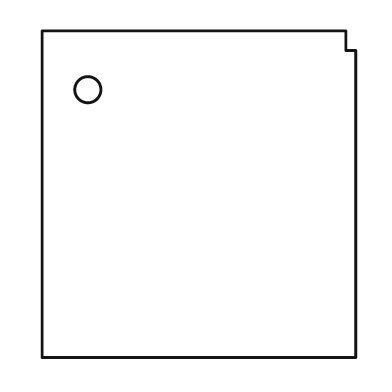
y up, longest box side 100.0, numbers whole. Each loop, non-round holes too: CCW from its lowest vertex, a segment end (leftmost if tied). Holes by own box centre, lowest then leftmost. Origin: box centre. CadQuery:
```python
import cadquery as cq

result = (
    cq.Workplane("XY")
    .moveTo(-48.0, -50.0)
    .lineTo(48.0, -50.0)
    .lineTo(48.0, 44.0)
    .lineTo(45.0, 44.0)
    .lineTo(45.0, 50.0)
    .lineTo(-48.0, 50.0)
    .close()
    .moveTo(-34.0, 32.0)
    .circle(4.0)
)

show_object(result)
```